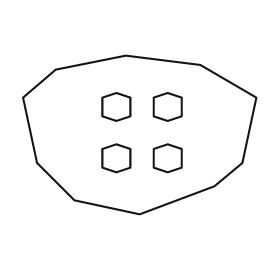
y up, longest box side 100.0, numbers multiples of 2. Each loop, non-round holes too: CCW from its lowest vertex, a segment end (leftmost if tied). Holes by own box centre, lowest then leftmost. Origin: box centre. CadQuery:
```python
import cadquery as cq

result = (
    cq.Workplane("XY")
    .moveTo(0.0, -34.0)
    .lineTo(32.0, -22.0)
    .lineTo(44.0, -12.0)
    .lineTo(50.0, 16.0)
    .lineTo(26.0, 30.0)
    .lineTo(-6.0, 34.0)
    .lineTo(-36.0, 28.0)
    .lineTo(-50.0, 16.0)
    .lineTo(-44.0, -12.0)
    .lineTo(-28.0, -28.0)
    .close()
    .moveTo(-10.0, -16.0)
    .lineTo(-4.0, -14.0)
    .lineTo(-4.0, -6.0)
    .lineTo(-10.0, -4.0)
    .lineTo(-16.0, -6.0)
    .lineTo(-16.0, -14.0)
    .close()
    .moveTo(12.0, -16.0)
    .lineTo(18.0, -14.0)
    .lineTo(18.0, -6.0)
    .lineTo(12.0, -4.0)
    .lineTo(6.0, -6.0)
    .lineTo(6.0, -14.0)
    .close()
    .moveTo(-10.0, 6.0)
    .lineTo(-4.0, 8.0)
    .lineTo(-4.0, 16.0)
    .lineTo(-10.0, 18.0)
    .lineTo(-16.0, 16.0)
    .lineTo(-16.0, 8.0)
    .close()
    .moveTo(12.0, 6.0)
    .lineTo(18.0, 8.0)
    .lineTo(18.0, 16.0)
    .lineTo(12.0, 18.0)
    .lineTo(6.0, 16.0)
    .lineTo(6.0, 8.0)
    .close()
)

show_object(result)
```